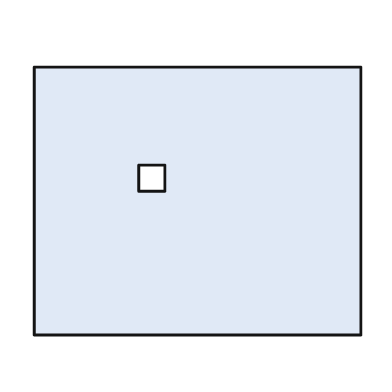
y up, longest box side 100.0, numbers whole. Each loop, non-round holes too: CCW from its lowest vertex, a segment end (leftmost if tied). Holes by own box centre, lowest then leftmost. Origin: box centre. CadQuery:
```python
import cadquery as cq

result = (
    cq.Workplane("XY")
    .moveTo(-50.0, -41.0)
    .lineTo(50.0, -41.0)
    .lineTo(50.0, 41.0)
    .lineTo(-50.0, 41.0)
    .close()
    .moveTo(-18.0, 3.0)
    .lineTo(-10.0, 3.0)
    .lineTo(-10.0, 11.0)
    .lineTo(-18.0, 11.0)
    .close()
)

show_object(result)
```